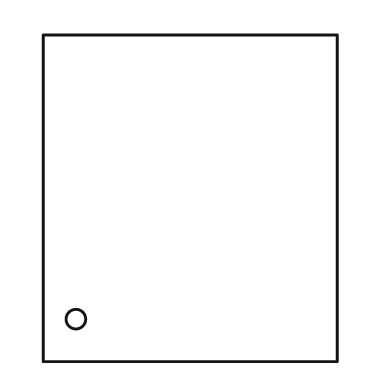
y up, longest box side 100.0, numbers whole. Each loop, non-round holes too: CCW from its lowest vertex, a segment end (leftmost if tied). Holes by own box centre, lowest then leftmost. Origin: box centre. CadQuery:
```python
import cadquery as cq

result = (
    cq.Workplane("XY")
    .moveTo(-45.0, -50.0)
    .lineTo(45.0, -50.0)
    .lineTo(45.0, 50.0)
    .lineTo(-45.0, 50.0)
    .close()
    .moveTo(-35.0, -37.0)
    .circle(3.0)
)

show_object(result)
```